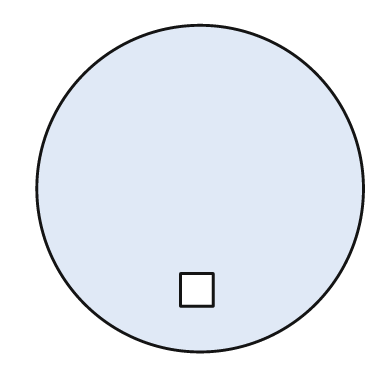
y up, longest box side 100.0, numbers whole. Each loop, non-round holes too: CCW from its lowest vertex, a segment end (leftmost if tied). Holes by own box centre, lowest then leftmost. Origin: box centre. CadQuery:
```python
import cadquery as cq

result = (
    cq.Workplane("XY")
    .moveTo(0.0, 0.0)
    .circle(50.0)
    .moveTo(-6.0, -36.0)
    .lineTo(4.0, -36.0)
    .lineTo(4.0, -26.0)
    .lineTo(-6.0, -26.0)
    .close()
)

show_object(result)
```